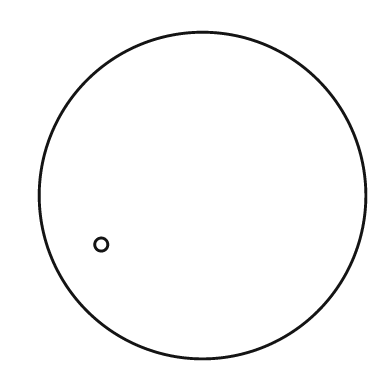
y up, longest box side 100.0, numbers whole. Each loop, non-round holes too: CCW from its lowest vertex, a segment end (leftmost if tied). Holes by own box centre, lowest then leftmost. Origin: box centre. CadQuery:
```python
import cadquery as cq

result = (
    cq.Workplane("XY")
    .moveTo(0.0, 0.0)
    .circle(50.0)
    .moveTo(-31.0, -15.0)
    .circle(2.0)
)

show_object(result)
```